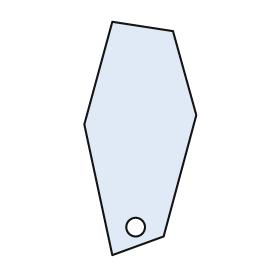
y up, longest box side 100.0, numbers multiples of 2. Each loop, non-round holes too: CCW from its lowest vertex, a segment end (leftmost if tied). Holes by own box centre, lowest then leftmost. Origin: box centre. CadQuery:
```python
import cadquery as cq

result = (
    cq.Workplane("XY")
    .moveTo(-12.0, -50.0)
    .lineTo(10.0, -42.0)
    .lineTo(24.0, 10.0)
    .lineTo(14.0, 46.0)
    .lineTo(-12.0, 50.0)
    .lineTo(-24.0, 6.0)
    .close()
    .moveTo(-2.0, -38.0)
    .circle(4.0)
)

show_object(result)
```